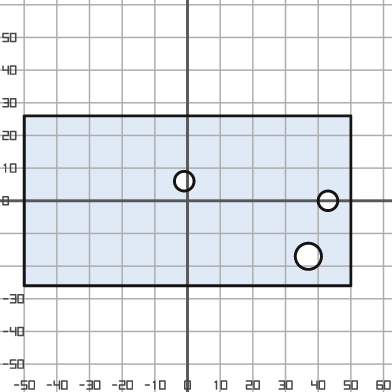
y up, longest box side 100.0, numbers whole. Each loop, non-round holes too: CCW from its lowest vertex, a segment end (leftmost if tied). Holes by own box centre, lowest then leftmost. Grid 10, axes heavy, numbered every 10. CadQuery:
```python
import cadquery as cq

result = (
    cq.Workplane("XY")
    .moveTo(-50.0, -26.0)
    .lineTo(50.0, -26.0)
    .lineTo(50.0, 26.0)
    .lineTo(-50.0, 26.0)
    .close()
    .moveTo(37.0, -17.0)
    .circle(4.0)
    .moveTo(43.0, 0.0)
    .circle(3.0)
    .moveTo(-1.0, 6.0)
    .circle(3.0)
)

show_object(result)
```